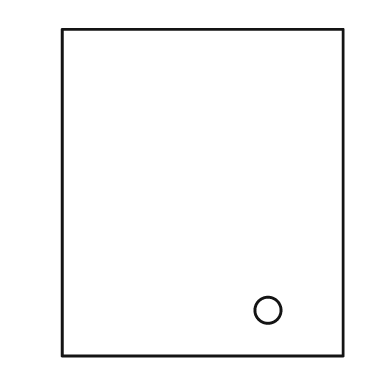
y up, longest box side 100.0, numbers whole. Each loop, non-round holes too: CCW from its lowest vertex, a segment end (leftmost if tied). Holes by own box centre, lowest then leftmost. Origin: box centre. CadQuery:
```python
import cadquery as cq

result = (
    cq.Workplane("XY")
    .moveTo(-43.0, -50.0)
    .lineTo(43.0, -50.0)
    .lineTo(43.0, 50.0)
    .lineTo(-43.0, 50.0)
    .close()
    .moveTo(20.0, -36.0)
    .circle(4.0)
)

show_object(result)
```